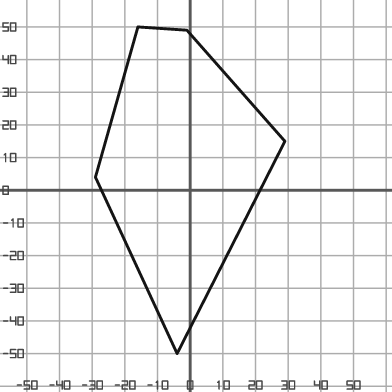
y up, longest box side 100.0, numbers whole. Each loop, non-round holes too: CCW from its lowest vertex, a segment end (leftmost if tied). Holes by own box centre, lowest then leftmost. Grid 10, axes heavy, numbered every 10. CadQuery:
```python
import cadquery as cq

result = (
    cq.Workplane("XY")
    .moveTo(-4.0, -50.0)
    .lineTo(29.0, 15.0)
    .lineTo(-1.0, 49.0)
    .lineTo(-16.0, 50.0)
    .lineTo(-29.0, 4.0)
    .close()
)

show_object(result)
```